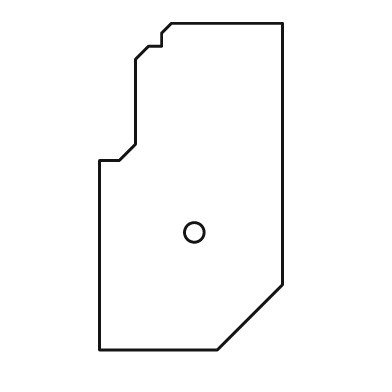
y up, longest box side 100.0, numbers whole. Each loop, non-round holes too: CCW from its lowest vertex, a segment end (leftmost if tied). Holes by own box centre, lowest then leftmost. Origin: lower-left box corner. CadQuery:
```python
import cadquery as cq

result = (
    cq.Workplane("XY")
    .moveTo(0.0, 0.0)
    .lineTo(36.0, 0.0)
    .lineTo(56.0, 20.0)
    .lineTo(56.0, 100.0)
    .lineTo(22.0, 100.0)
    .lineTo(19.0, 97.0)
    .lineTo(19.0, 93.0)
    .lineTo(15.0, 93.0)
    .lineTo(11.0, 89.0)
    .lineTo(11.0, 63.0)
    .lineTo(6.0, 58.0)
    .lineTo(0.0, 58.0)
    .close()
    .moveTo(29.0, 36.0)
    .circle(3.0)
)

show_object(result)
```